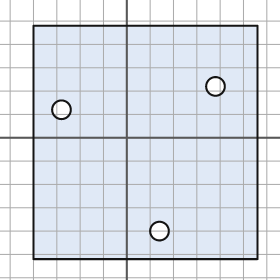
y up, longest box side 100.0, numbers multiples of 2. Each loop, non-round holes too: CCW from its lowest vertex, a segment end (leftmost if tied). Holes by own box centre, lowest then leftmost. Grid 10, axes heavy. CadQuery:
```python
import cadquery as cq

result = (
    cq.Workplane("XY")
    .moveTo(-40.0, -52.0)
    .lineTo(56.0, -52.0)
    .lineTo(56.0, 48.0)
    .lineTo(-40.0, 48.0)
    .close()
    .moveTo(14.0, -40.0)
    .circle(4.0)
    .moveTo(-28.0, 12.0)
    .circle(4.0)
    .moveTo(38.0, 22.0)
    .circle(4.0)
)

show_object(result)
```